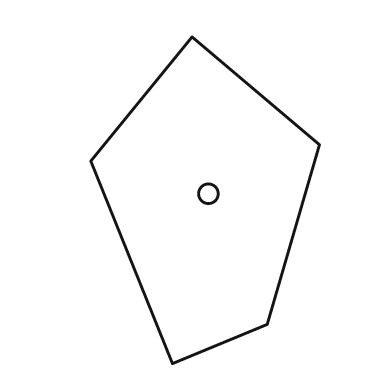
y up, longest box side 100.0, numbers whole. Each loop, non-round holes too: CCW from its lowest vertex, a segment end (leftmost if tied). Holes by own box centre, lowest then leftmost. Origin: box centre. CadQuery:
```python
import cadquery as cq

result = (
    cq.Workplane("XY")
    .moveTo(-10.0, -50.0)
    .lineTo(19.0, -38.0)
    .lineTo(35.0, 17.0)
    .lineTo(-4.0, 50.0)
    .lineTo(-35.0, 12.0)
    .close()
    .moveTo(1.0, 2.0)
    .circle(3.0)
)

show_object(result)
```